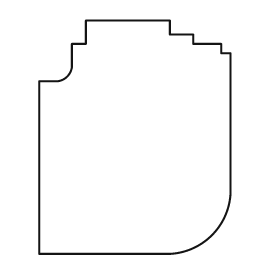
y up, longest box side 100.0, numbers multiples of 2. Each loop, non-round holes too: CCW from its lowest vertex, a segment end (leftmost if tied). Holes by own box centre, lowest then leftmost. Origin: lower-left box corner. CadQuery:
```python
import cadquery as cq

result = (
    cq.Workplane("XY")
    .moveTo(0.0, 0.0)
    .lineTo(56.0, 0.0)
    .threePointArc((74.0, 8.0), (82.0, 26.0))
    .lineTo(82.0, 86.0)
    .lineTo(78.0, 86.0)
    .lineTo(78.0, 90.0)
    .lineTo(66.0, 90.0)
    .lineTo(66.0, 94.0)
    .lineTo(56.0, 94.0)
    .lineTo(56.0, 100.0)
    .lineTo(20.0, 100.0)
    .lineTo(20.0, 90.0)
    .lineTo(14.0, 90.0)
    .lineTo(14.0, 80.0)
    .threePointArc((12.0, 76.0), (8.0, 74.0))
    .lineTo(0.0, 74.0)
    .close()
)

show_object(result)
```